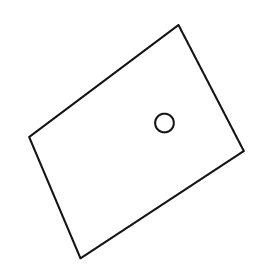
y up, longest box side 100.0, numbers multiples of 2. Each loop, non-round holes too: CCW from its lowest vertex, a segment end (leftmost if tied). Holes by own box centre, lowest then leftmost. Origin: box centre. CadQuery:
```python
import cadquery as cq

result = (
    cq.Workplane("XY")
    .moveTo(-24.0, -50.0)
    .lineTo(46.0, -4.0)
    .lineTo(18.0, 50.0)
    .lineTo(-46.0, 2.0)
    .close()
    .moveTo(12.0, 8.0)
    .circle(4.0)
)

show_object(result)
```